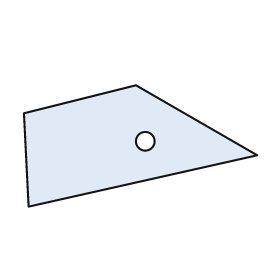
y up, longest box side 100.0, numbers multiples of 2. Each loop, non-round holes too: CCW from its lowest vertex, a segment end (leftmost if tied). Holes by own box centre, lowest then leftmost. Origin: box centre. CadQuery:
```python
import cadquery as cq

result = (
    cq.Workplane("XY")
    .moveTo(-48.0, -26.0)
    .lineTo(50.0, -4.0)
    .lineTo(-2.0, 26.0)
    .lineTo(-50.0, 14.0)
    .close()
    .moveTo(2.0, 2.0)
    .circle(4.0)
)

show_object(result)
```